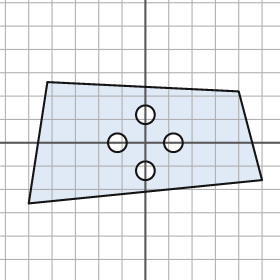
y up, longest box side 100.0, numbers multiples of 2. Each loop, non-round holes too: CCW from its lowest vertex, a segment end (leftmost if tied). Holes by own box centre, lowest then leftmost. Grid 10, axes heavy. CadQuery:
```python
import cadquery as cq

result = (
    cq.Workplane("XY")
    .moveTo(-50.0, -26.0)
    .lineTo(50.0, -16.0)
    .lineTo(40.0, 22.0)
    .lineTo(-42.0, 26.0)
    .close()
    .moveTo(0.0, -12.0)
    .circle(4.0)
    .moveTo(-12.0, 0.0)
    .circle(4.0)
    .moveTo(12.0, 0.0)
    .circle(4.0)
    .moveTo(0.0, 12.0)
    .circle(4.0)
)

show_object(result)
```